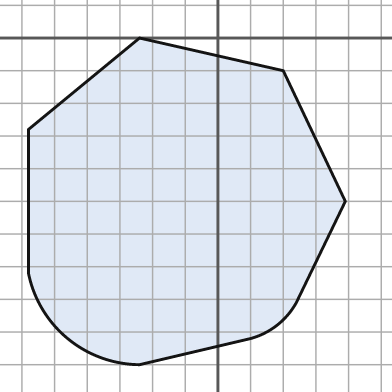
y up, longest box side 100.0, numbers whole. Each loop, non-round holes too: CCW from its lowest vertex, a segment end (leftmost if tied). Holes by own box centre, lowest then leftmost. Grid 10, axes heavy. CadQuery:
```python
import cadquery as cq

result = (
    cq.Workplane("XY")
    .moveTo(-24.0, -100.0)
    .lineTo(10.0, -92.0)
    .threePointArc((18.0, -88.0), (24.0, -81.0))
    .lineTo(39.0, -50.0)
    .lineTo(20.0, -10.0)
    .lineTo(-24.0, 0.0)
    .lineTo(-58.0, -28.0)
    .lineTo(-58.0, -72.0)
    .threePointArc((-46.0, -92.0), (-24.0, -100.0))
    .close()
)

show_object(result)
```